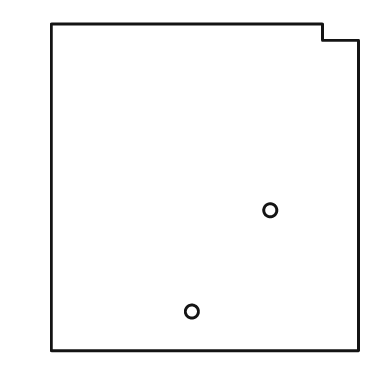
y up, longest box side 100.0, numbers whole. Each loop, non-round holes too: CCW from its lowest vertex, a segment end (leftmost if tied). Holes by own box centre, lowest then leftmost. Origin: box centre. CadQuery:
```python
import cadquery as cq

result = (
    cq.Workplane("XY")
    .moveTo(-47.0, -50.0)
    .lineTo(47.0, -50.0)
    .lineTo(47.0, 45.0)
    .lineTo(36.0, 45.0)
    .lineTo(36.0, 50.0)
    .lineTo(-47.0, 50.0)
    .close()
    .moveTo(-4.0, -38.0)
    .circle(2.0)
    .moveTo(20.0, -7.0)
    .circle(2.0)
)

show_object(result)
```